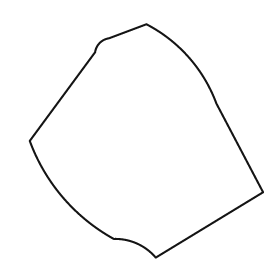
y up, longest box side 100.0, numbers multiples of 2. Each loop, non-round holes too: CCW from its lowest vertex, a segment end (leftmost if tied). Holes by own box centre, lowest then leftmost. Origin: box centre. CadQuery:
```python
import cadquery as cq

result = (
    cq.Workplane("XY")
    .moveTo(4.0, -50.0)
    .lineTo(50.0, -22.0)
    .lineTo(30.0, 16.0)
    .threePointArc((18.0, 36.0), (0.0, 50.0))
    .lineTo(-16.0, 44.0)
    .threePointArc((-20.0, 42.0), (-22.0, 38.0))
    .lineTo(-50.0, 0.0)
    .threePointArc((-36.0, -24.0), (-14.0, -42.0))
    .threePointArc((-4.0, -44.0), (4.0, -50.0))
    .close()
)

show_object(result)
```